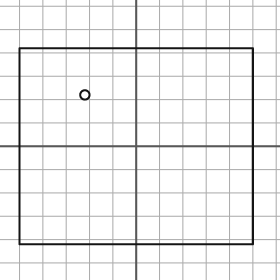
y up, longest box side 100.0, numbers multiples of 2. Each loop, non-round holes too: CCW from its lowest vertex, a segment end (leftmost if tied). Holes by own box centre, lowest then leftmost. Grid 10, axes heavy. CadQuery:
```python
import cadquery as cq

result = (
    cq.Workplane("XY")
    .moveTo(-50.0, -42.0)
    .lineTo(50.0, -42.0)
    .lineTo(50.0, 42.0)
    .lineTo(-50.0, 42.0)
    .close()
    .moveTo(-22.0, 22.0)
    .circle(2.0)
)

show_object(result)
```